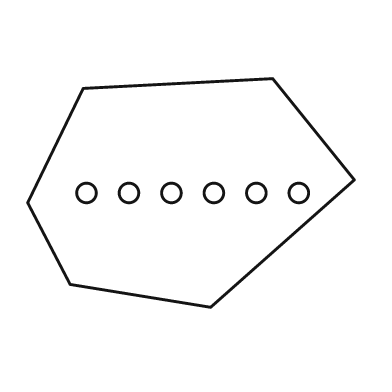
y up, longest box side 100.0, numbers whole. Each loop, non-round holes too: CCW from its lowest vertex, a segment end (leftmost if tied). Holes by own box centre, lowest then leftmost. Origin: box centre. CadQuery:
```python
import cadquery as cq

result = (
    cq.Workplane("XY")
    .moveTo(6.0, -35.0)
    .lineTo(50.0, 4.0)
    .lineTo(25.0, 35.0)
    .lineTo(-33.0, 32.0)
    .lineTo(-50.0, -3.0)
    .lineTo(-37.0, -28.0)
    .close()
    .moveTo(-32.0, 0.0)
    .circle(3.0)
    .moveTo(-19.0, 0.0)
    .circle(3.0)
    .moveTo(-6.0, 0.0)
    .circle(3.0)
    .moveTo(7.0, 0.0)
    .circle(3.0)
    .moveTo(20.0, 0.0)
    .circle(3.0)
    .moveTo(33.0, 0.0)
    .circle(3.0)
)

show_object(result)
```